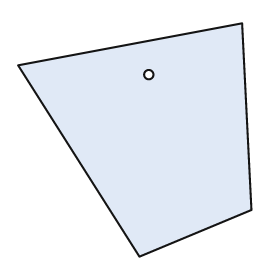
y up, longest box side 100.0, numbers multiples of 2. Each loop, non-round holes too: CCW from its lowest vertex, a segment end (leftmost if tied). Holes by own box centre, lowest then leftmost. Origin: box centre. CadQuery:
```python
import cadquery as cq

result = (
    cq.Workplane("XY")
    .moveTo(2.0, -50.0)
    .lineTo(50.0, -30.0)
    .lineTo(46.0, 50.0)
    .lineTo(-50.0, 32.0)
    .close()
    .moveTo(6.0, 28.0)
    .circle(2.0)
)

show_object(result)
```